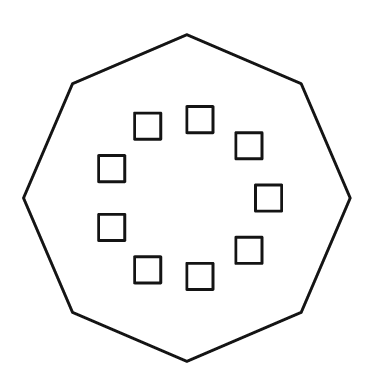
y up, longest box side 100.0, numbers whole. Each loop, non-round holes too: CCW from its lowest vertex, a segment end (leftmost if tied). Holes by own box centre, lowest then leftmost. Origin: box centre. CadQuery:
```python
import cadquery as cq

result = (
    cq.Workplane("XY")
    .moveTo(0.0, -50.0)
    .lineTo(35.0, -35.0)
    .lineTo(50.0, 0.0)
    .lineTo(35.0, 35.0)
    .lineTo(0.0, 50.0)
    .lineTo(-35.0, 35.0)
    .lineTo(-50.0, 0.0)
    .lineTo(-35.0, -35.0)
    .close()
    .moveTo(0.0, -28.0)
    .lineTo(8.0, -28.0)
    .lineTo(8.0, -20.0)
    .lineTo(0.0, -20.0)
    .close()
    .moveTo(-16.0, -26.0)
    .lineTo(-8.0, -26.0)
    .lineTo(-8.0, -18.0)
    .lineTo(-16.0, -18.0)
    .close()
    .moveTo(15.0, -20.0)
    .lineTo(23.0, -20.0)
    .lineTo(23.0, -12.0)
    .lineTo(15.0, -12.0)
    .close()
    .moveTo(-27.0, -13.0)
    .lineTo(-19.0, -13.0)
    .lineTo(-19.0, -5.0)
    .lineTo(-27.0, -5.0)
    .close()
    .moveTo(21.0, -4.0)
    .lineTo(29.0, -4.0)
    .lineTo(29.0, 4.0)
    .lineTo(21.0, 4.0)
    .close()
    .moveTo(-27.0, 5.0)
    .lineTo(-19.0, 5.0)
    .lineTo(-19.0, 13.0)
    .lineTo(-27.0, 13.0)
    .close()
    .moveTo(15.0, 12.0)
    .lineTo(23.0, 12.0)
    .lineTo(23.0, 20.0)
    .lineTo(15.0, 20.0)
    .close()
    .moveTo(-16.0, 18.0)
    .lineTo(-8.0, 18.0)
    .lineTo(-8.0, 26.0)
    .lineTo(-16.0, 26.0)
    .close()
    .moveTo(0.0, 20.0)
    .lineTo(8.0, 20.0)
    .lineTo(8.0, 28.0)
    .lineTo(0.0, 28.0)
    .close()
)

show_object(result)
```